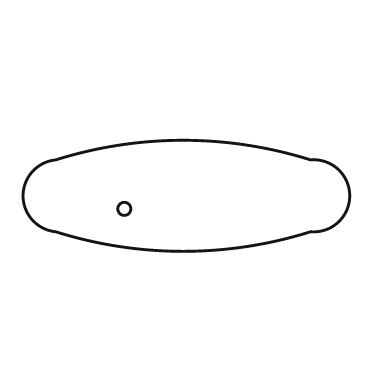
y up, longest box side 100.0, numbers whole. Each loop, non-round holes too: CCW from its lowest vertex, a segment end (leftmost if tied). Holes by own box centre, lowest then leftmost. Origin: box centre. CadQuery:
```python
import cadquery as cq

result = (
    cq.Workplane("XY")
    .moveTo(-40.0, -11.0)
    .threePointArc((-1.0, -17.0), (38.0, -11.0))
    .threePointArc((50.0, 0.0), (38.0, 11.0))
    .threePointArc((-1.0, 17.0), (-40.0, 11.0))
    .threePointArc((-50.0, 0.0), (-40.0, -11.0))
    .close()
    .moveTo(-19.0, -4.0)
    .circle(2.0)
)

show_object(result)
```